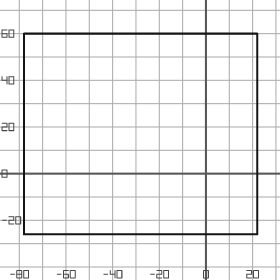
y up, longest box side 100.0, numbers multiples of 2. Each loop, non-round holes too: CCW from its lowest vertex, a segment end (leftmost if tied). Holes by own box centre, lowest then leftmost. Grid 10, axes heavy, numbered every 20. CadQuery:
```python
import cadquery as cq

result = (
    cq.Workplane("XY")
    .moveTo(-78.0, -26.0)
    .lineTo(22.0, -26.0)
    .lineTo(22.0, 60.0)
    .lineTo(-78.0, 60.0)
    .close()
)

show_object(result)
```